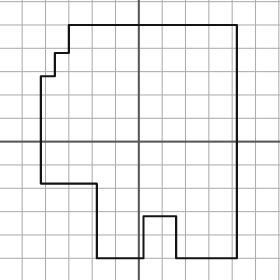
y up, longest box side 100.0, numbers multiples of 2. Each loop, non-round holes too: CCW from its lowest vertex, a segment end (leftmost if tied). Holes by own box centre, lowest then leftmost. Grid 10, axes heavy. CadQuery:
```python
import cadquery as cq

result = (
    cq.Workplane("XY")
    .moveTo(-18.0, -50.0)
    .lineTo(2.0, -50.0)
    .lineTo(2.0, -32.0)
    .lineTo(16.0, -32.0)
    .lineTo(16.0, -50.0)
    .lineTo(42.0, -50.0)
    .lineTo(42.0, 50.0)
    .lineTo(-30.0, 50.0)
    .lineTo(-30.0, 38.0)
    .lineTo(-36.0, 38.0)
    .lineTo(-36.0, 28.0)
    .lineTo(-42.0, 28.0)
    .lineTo(-42.0, -18.0)
    .lineTo(-18.0, -18.0)
    .close()
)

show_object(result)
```